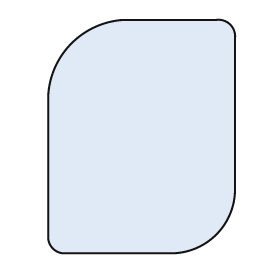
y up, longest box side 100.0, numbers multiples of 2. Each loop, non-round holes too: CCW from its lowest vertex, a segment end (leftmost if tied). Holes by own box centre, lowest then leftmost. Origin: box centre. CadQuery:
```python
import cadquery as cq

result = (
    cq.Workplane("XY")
    .moveTo(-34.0, -50.0)
    .lineTo(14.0, -50.0)
    .threePointArc((32.0, -42.0), (40.0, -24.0))
    .lineTo(40.0, 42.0)
    .threePointArc((38.0, 48.0), (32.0, 50.0))
    .lineTo(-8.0, 50.0)
    .threePointArc((-30.0, 40.0), (-40.0, 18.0))
    .lineTo(-40.0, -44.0)
    .threePointArc((-38.0, -48.0), (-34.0, -50.0))
    .close()
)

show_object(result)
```